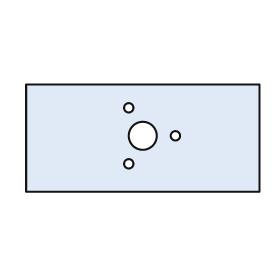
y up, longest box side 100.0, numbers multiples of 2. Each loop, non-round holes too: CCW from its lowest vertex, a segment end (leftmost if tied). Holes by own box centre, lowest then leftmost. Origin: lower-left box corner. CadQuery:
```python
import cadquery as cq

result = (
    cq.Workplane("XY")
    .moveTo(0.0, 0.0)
    .lineTo(100.0, 0.0)
    .lineTo(100.0, 46.0)
    .lineTo(0.0, 46.0)
    .close()
    .moveTo(44.0, 12.0)
    .circle(2.0)
    .moveTo(50.0, 24.0)
    .circle(6.0)
    .moveTo(64.0, 24.0)
    .circle(2.0)
    .moveTo(44.0, 36.0)
    .circle(2.0)
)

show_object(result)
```